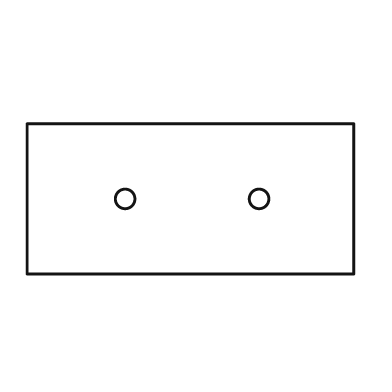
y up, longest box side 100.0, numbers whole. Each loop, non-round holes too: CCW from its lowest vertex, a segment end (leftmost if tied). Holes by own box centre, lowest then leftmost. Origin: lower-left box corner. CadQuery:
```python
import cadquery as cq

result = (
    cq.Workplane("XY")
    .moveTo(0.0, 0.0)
    .lineTo(100.0, 0.0)
    .lineTo(100.0, 46.0)
    .lineTo(0.0, 46.0)
    .close()
    .moveTo(30.0, 23.0)
    .circle(3.0)
    .moveTo(71.0, 23.0)
    .circle(3.0)
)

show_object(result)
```